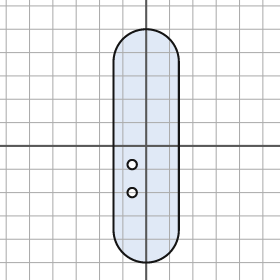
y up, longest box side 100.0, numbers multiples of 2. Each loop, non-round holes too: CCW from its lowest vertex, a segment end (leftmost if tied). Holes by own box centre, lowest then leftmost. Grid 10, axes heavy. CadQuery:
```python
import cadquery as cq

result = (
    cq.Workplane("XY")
    .moveTo(-14.0, -36.0)
    .threePointArc((0.0, -50.0), (14.0, -36.0))
    .lineTo(14.0, 36.0)
    .threePointArc((0.0, 50.0), (-14.0, 36.0))
    .close()
    .moveTo(-6.0, -20.0)
    .circle(2.0)
    .moveTo(-6.0, -8.0)
    .circle(2.0)
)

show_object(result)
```